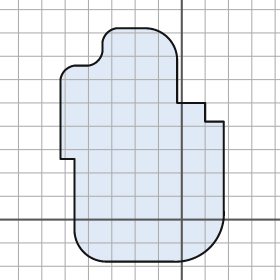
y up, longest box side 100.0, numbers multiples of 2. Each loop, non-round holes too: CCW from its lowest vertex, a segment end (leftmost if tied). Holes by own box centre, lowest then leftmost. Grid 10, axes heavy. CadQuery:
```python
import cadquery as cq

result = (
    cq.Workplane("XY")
    .moveTo(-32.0, -18.0)
    .lineTo(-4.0, -18.0)
    .threePointArc((12.0, -12.0), (18.0, 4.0))
    .lineTo(18.0, 42.0)
    .lineTo(10.0, 42.0)
    .lineTo(10.0, 50.0)
    .lineTo(-2.0, 50.0)
    .lineTo(-2.0, 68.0)
    .threePointArc((-6.0, 78.0), (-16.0, 82.0))
    .lineTo(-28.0, 82.0)
    .threePointArc((-32.0, 80.0), (-34.0, 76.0))
    .lineTo(-34.0, 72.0)
    .threePointArc((-36.0, 68.0), (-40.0, 66.0))
    .lineTo(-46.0, 66.0)
    .threePointArc((-50.0, 64.0), (-52.0, 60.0))
    .lineTo(-52.0, 26.0)
    .lineTo(-46.0, 26.0)
    .lineTo(-46.0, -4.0)
    .threePointArc((-42.0, -14.0), (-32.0, -18.0))
    .close()
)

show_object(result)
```